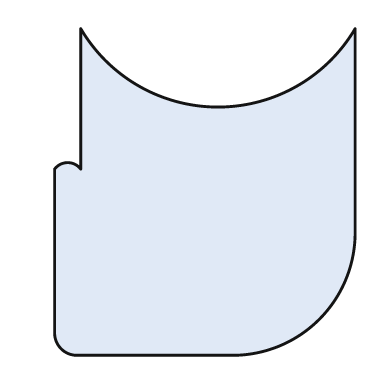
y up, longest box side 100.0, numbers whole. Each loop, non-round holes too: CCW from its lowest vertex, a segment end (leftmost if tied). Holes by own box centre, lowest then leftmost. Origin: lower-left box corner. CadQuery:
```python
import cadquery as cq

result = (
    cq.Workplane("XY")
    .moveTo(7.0, 0.0)
    .lineTo(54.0, 0.0)
    .threePointArc((81.0, 11.0), (92.0, 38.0))
    .lineTo(92.0, 100.0)
    .threePointArc((50.0, 76.0), (8.0, 100.0))
    .lineTo(8.0, 57.0)
    .threePointArc((4.0, 59.0), (0.0, 57.0))
    .lineTo(0.0, 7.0)
    .threePointArc((2.0, 2.0), (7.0, 0.0))
    .close()
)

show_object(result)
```